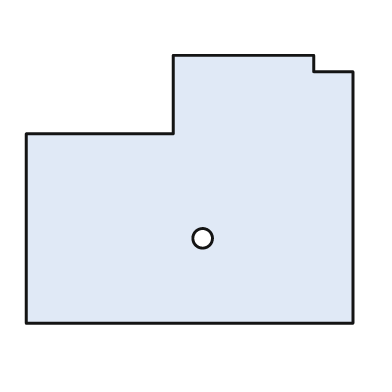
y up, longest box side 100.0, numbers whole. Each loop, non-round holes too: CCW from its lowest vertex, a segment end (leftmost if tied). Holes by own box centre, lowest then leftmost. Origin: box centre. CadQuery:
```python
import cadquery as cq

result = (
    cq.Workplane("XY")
    .moveTo(-50.0, -41.0)
    .lineTo(50.0, -41.0)
    .lineTo(50.0, 36.0)
    .lineTo(38.0, 36.0)
    .lineTo(38.0, 41.0)
    .lineTo(-5.0, 41.0)
    .lineTo(-5.0, 17.0)
    .lineTo(-50.0, 17.0)
    .close()
    .moveTo(4.0, -15.0)
    .circle(3.0)
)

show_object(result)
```